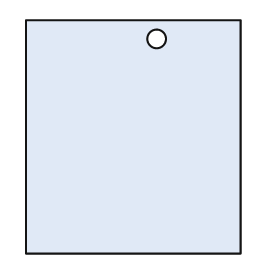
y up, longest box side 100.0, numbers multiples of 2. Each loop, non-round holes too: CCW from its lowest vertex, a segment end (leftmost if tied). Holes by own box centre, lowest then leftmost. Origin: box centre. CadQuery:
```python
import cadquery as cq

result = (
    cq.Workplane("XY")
    .moveTo(-46.0, -50.0)
    .lineTo(46.0, -50.0)
    .lineTo(46.0, 50.0)
    .lineTo(-46.0, 50.0)
    .close()
    .moveTo(10.0, 42.0)
    .circle(4.0)
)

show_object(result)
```